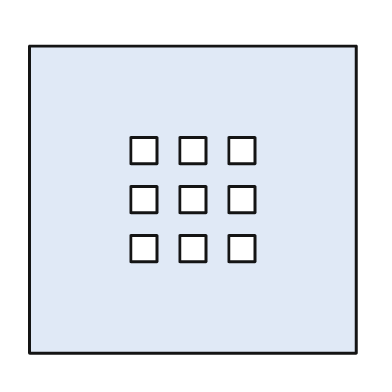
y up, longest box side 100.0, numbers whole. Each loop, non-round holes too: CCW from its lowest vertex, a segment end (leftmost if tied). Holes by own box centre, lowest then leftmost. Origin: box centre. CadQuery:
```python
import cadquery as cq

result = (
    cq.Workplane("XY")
    .moveTo(-50.0, -47.0)
    .lineTo(50.0, -47.0)
    .lineTo(50.0, 47.0)
    .lineTo(-50.0, 47.0)
    .close()
    .moveTo(-19.0, -19.0)
    .lineTo(-11.0, -19.0)
    .lineTo(-11.0, -11.0)
    .lineTo(-19.0, -11.0)
    .close()
    .moveTo(-4.0, -19.0)
    .lineTo(4.0, -19.0)
    .lineTo(4.0, -11.0)
    .lineTo(-4.0, -11.0)
    .close()
    .moveTo(11.0, -19.0)
    .lineTo(19.0, -19.0)
    .lineTo(19.0, -11.0)
    .lineTo(11.0, -11.0)
    .close()
    .moveTo(-19.0, -4.0)
    .lineTo(-11.0, -4.0)
    .lineTo(-11.0, 4.0)
    .lineTo(-19.0, 4.0)
    .close()
    .moveTo(-4.0, -4.0)
    .lineTo(4.0, -4.0)
    .lineTo(4.0, 4.0)
    .lineTo(-4.0, 4.0)
    .close()
    .moveTo(11.0, -4.0)
    .lineTo(19.0, -4.0)
    .lineTo(19.0, 4.0)
    .lineTo(11.0, 4.0)
    .close()
    .moveTo(-19.0, 11.0)
    .lineTo(-11.0, 11.0)
    .lineTo(-11.0, 19.0)
    .lineTo(-19.0, 19.0)
    .close()
    .moveTo(-4.0, 11.0)
    .lineTo(4.0, 11.0)
    .lineTo(4.0, 19.0)
    .lineTo(-4.0, 19.0)
    .close()
    .moveTo(11.0, 11.0)
    .lineTo(19.0, 11.0)
    .lineTo(19.0, 19.0)
    .lineTo(11.0, 19.0)
    .close()
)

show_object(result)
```